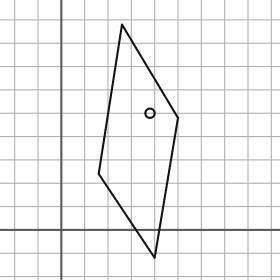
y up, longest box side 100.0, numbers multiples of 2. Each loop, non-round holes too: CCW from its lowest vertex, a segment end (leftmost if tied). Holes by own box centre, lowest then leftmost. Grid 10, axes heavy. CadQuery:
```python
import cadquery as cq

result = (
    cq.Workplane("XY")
    .moveTo(40.0, -12.0)
    .lineTo(50.0, 48.0)
    .lineTo(26.0, 88.0)
    .lineTo(16.0, 24.0)
    .close()
    .moveTo(38.0, 50.0)
    .circle(2.0)
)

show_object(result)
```